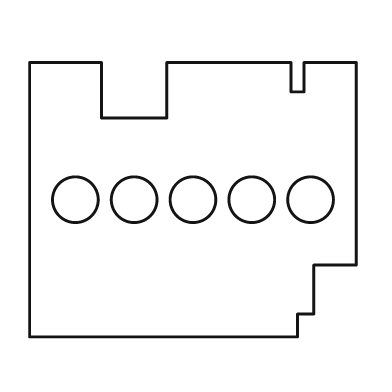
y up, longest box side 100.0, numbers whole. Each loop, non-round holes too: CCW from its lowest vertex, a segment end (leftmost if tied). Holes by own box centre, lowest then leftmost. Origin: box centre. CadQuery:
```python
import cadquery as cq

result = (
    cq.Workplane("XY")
    .moveTo(-50.0, -42.0)
    .lineTo(32.0, -42.0)
    .lineTo(32.0, -35.0)
    .lineTo(37.0, -35.0)
    .lineTo(37.0, -20.0)
    .lineTo(50.0, -20.0)
    .lineTo(50.0, 42.0)
    .lineTo(34.0, 42.0)
    .lineTo(34.0, 33.0)
    .lineTo(30.0, 33.0)
    .lineTo(30.0, 42.0)
    .lineTo(-8.0, 42.0)
    .lineTo(-8.0, 25.0)
    .lineTo(-28.0, 25.0)
    .lineTo(-28.0, 42.0)
    .lineTo(-50.0, 42.0)
    .close()
    .moveTo(-36.0, 0.0)
    .circle(7.0)
    .moveTo(-18.0, 0.0)
    .circle(7.0)
    .moveTo(0.0, 0.0)
    .circle(7.0)
    .moveTo(18.0, 0.0)
    .circle(7.0)
    .moveTo(36.0, 0.0)
    .circle(7.0)
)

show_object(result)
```